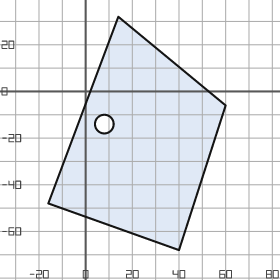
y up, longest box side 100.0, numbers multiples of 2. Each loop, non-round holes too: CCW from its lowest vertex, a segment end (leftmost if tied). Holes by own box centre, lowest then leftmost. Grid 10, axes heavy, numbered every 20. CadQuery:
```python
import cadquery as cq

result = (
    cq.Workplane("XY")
    .moveTo(40.0, -68.0)
    .lineTo(60.0, -6.0)
    .lineTo(14.0, 32.0)
    .lineTo(-16.0, -48.0)
    .close()
    .moveTo(8.0, -14.0)
    .circle(4.0)
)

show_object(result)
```